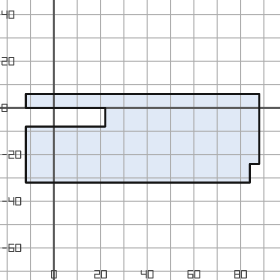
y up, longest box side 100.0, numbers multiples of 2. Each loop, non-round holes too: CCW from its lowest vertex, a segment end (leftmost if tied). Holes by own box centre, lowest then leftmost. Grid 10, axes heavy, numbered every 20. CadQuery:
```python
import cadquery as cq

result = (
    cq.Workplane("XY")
    .moveTo(-12.0, -32.0)
    .lineTo(84.0, -32.0)
    .lineTo(84.0, -24.0)
    .lineTo(88.0, -24.0)
    .lineTo(88.0, 6.0)
    .lineTo(-12.0, 6.0)
    .lineTo(-12.0, 0.0)
    .lineTo(22.0, 0.0)
    .lineTo(22.0, -8.0)
    .lineTo(-12.0, -8.0)
    .close()
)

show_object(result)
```